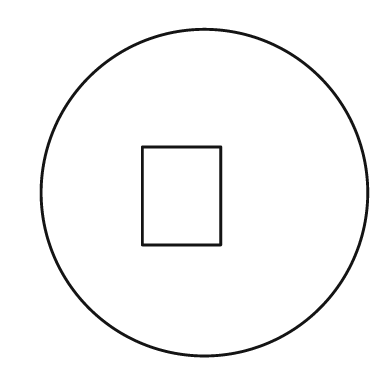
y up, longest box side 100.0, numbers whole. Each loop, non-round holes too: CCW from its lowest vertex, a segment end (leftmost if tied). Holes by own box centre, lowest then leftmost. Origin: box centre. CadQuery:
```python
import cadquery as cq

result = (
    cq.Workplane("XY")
    .moveTo(0.0, 0.0)
    .circle(50.0)
    .moveTo(-19.0, -16.0)
    .lineTo(5.0, -16.0)
    .lineTo(5.0, 14.0)
    .lineTo(-19.0, 14.0)
    .close()
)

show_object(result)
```